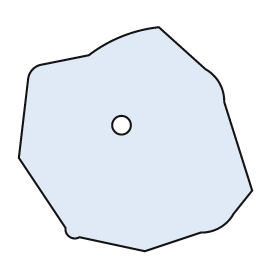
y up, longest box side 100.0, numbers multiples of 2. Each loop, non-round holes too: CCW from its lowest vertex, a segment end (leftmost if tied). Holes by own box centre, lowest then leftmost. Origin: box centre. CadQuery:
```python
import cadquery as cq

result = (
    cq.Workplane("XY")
    .moveTo(4.0, -48.0)
    .lineTo(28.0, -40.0)
    .threePointArc((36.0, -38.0), (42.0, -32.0))
    .lineTo(50.0, -22.0)
    .lineTo(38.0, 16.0)
    .threePointArc((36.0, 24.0), (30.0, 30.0))
    .lineTo(10.0, 48.0)
    .threePointArc((-6.0, 44.0), (-20.0, 36.0))
    .lineTo(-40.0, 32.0)
    .threePointArc((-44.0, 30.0), (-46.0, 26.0))
    .lineTo(-50.0, -8.0)
    .lineTo(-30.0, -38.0)
    .threePointArc((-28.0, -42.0), (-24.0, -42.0))
    .close()
    .moveTo(-6.0, 6.0)
    .circle(4.0)
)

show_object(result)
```